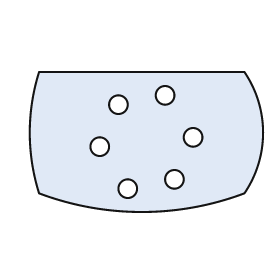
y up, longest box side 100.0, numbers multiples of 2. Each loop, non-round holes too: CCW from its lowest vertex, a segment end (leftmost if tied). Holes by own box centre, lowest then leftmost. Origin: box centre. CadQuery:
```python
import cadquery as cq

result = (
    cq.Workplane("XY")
    .moveTo(-46.0, -22.0)
    .threePointArc((-2.0, -30.0), (42.0, -22.0))
    .threePointArc((50.0, 4.0), (42.0, 30.0))
    .lineTo(-46.0, 30.0)
    .threePointArc((-50.0, 4.0), (-46.0, -22.0))
    .close()
    .moveTo(-8.0, -20.0)
    .circle(4.0)
    .moveTo(12.0, -16.0)
    .circle(4.0)
    .moveTo(-20.0, -2.0)
    .circle(4.0)
    .moveTo(20.0, 2.0)
    .circle(4.0)
    .moveTo(-12.0, 16.0)
    .circle(4.0)
    .moveTo(8.0, 20.0)
    .circle(4.0)
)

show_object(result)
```